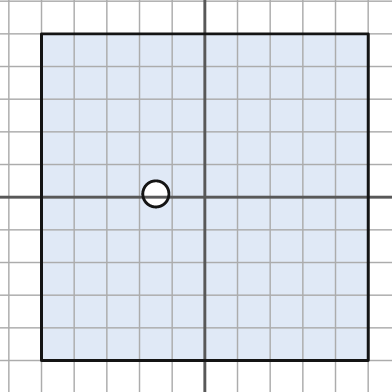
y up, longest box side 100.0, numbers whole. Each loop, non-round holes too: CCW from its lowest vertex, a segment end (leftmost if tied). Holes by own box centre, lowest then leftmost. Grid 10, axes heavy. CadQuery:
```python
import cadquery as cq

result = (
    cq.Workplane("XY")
    .moveTo(-50.0, -50.0)
    .lineTo(50.0, -50.0)
    .lineTo(50.0, 50.0)
    .lineTo(-50.0, 50.0)
    .close()
    .moveTo(-15.0, 1.0)
    .circle(4.0)
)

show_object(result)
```